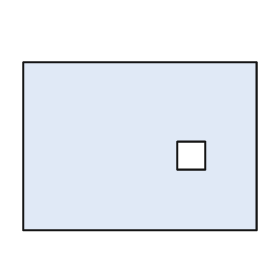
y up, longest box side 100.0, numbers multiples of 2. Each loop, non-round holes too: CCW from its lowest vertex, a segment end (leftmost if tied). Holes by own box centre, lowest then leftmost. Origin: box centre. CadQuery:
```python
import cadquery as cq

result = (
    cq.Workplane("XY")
    .moveTo(-50.0, -36.0)
    .lineTo(50.0, -36.0)
    .lineTo(50.0, 36.0)
    .lineTo(-50.0, 36.0)
    .close()
    .moveTo(16.0, -10.0)
    .lineTo(28.0, -10.0)
    .lineTo(28.0, 2.0)
    .lineTo(16.0, 2.0)
    .close()
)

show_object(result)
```